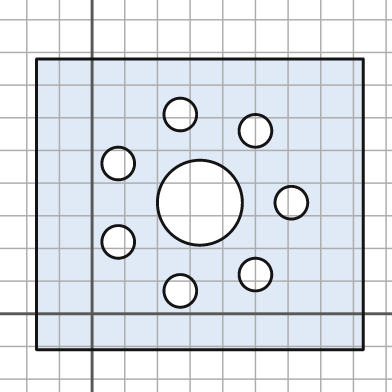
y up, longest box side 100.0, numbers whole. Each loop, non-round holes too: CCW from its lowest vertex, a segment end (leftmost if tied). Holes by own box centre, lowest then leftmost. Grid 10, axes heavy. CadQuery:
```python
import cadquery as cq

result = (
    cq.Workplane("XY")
    .moveTo(-17.0, -11.0)
    .lineTo(83.0, -11.0)
    .lineTo(83.0, 78.0)
    .lineTo(-17.0, 78.0)
    .close()
    .moveTo(27.0, 7.0)
    .circle(5.0)
    .moveTo(50.0, 12.0)
    .circle(5.0)
    .moveTo(8.0, 22.0)
    .circle(5.0)
    .moveTo(33.0, 34.0)
    .circle(13.0)
    .moveTo(61.0, 34.0)
    .circle(5.0)
    .moveTo(8.0, 46.0)
    .circle(5.0)
    .moveTo(50.0, 56.0)
    .circle(5.0)
    .moveTo(27.0, 61.0)
    .circle(5.0)
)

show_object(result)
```